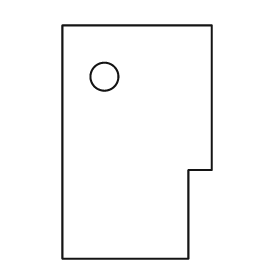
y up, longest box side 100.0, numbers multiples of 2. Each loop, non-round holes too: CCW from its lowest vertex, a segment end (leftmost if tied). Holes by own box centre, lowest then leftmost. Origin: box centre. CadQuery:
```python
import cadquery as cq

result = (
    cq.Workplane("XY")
    .moveTo(-32.0, -50.0)
    .lineTo(22.0, -50.0)
    .lineTo(22.0, -12.0)
    .lineTo(32.0, -12.0)
    .lineTo(32.0, 50.0)
    .lineTo(-32.0, 50.0)
    .close()
    .moveTo(-14.0, 28.0)
    .circle(6.0)
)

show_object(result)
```